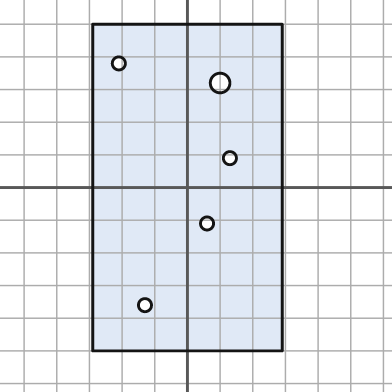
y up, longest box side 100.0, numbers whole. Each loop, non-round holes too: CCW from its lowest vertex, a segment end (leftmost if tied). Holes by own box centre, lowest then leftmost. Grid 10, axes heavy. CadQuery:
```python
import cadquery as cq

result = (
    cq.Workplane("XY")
    .moveTo(-29.0, -50.0)
    .lineTo(29.0, -50.0)
    .lineTo(29.0, 50.0)
    .lineTo(-29.0, 50.0)
    .close()
    .moveTo(-13.0, -36.0)
    .circle(2.0)
    .moveTo(6.0, -11.0)
    .circle(2.0)
    .moveTo(13.0, 9.0)
    .circle(2.0)
    .moveTo(10.0, 32.0)
    .circle(3.0)
    .moveTo(-21.0, 38.0)
    .circle(2.0)
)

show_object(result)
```